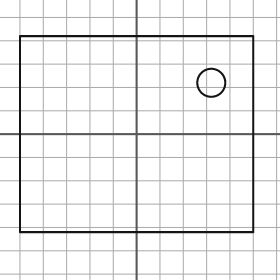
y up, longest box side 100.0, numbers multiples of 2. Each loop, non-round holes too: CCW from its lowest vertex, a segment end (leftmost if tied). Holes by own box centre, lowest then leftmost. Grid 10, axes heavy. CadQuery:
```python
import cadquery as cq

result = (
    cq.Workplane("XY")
    .moveTo(-50.0, -42.0)
    .lineTo(50.0, -42.0)
    .lineTo(50.0, 42.0)
    .lineTo(-50.0, 42.0)
    .close()
    .moveTo(32.0, 22.0)
    .circle(6.0)
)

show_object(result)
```